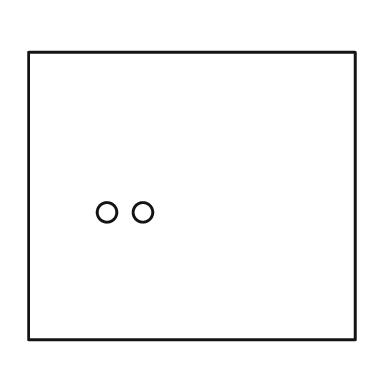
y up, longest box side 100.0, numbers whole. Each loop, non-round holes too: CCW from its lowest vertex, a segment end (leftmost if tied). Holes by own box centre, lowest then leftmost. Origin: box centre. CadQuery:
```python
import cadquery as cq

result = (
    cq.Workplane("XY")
    .moveTo(-50.0, -44.0)
    .lineTo(50.0, -44.0)
    .lineTo(50.0, 44.0)
    .lineTo(-50.0, 44.0)
    .close()
    .moveTo(-26.0, -5.0)
    .circle(3.0)
    .moveTo(-15.0, -5.0)
    .circle(3.0)
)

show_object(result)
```